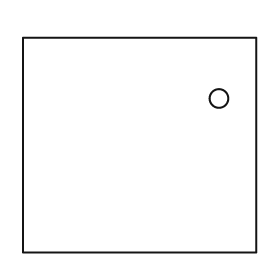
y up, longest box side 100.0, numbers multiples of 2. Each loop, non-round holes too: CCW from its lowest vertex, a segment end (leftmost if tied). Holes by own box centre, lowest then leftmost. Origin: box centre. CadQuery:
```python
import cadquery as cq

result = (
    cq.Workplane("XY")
    .moveTo(-50.0, -46.0)
    .lineTo(50.0, -46.0)
    .lineTo(50.0, 46.0)
    .lineTo(-50.0, 46.0)
    .close()
    .moveTo(34.0, 20.0)
    .circle(4.0)
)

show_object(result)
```